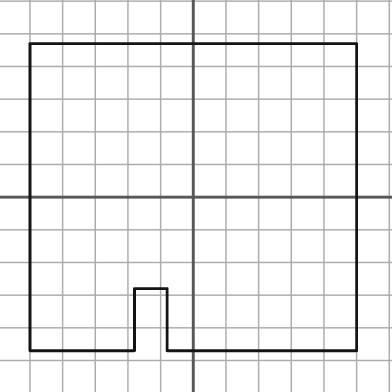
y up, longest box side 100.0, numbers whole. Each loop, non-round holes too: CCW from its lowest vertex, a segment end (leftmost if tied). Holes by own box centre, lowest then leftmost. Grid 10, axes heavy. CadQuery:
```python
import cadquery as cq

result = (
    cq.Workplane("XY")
    .moveTo(-50.0, -47.0)
    .lineTo(-18.0, -47.0)
    .lineTo(-18.0, -28.0)
    .lineTo(-8.0, -28.0)
    .lineTo(-8.0, -47.0)
    .lineTo(50.0, -47.0)
    .lineTo(50.0, 47.0)
    .lineTo(-50.0, 47.0)
    .close()
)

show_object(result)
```